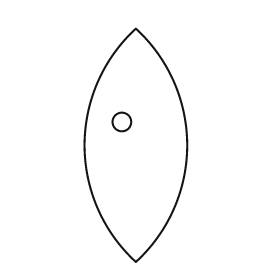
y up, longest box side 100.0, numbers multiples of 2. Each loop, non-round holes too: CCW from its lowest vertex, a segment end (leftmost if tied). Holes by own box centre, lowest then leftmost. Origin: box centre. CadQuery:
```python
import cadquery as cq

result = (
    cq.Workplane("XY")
    .moveTo(0.0, -50.0)
    .threePointArc((22.0, 0.0), (0.0, 50.0))
    .threePointArc((-22.0, 0.0), (0.0, -50.0))
    .close()
    .moveTo(-6.0, 10.0)
    .circle(4.0)
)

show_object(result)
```